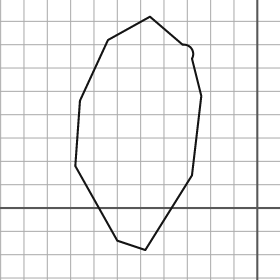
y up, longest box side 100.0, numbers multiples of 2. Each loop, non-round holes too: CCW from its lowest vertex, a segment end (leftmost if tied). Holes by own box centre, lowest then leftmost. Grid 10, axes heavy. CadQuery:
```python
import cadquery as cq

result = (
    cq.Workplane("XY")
    .moveTo(-48.0, -18.0)
    .lineTo(-28.0, 14.0)
    .lineTo(-24.0, 48.0)
    .lineTo(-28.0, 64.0)
    .threePointArc((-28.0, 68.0), (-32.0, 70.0))
    .lineTo(-46.0, 82.0)
    .lineTo(-64.0, 72.0)
    .lineTo(-76.0, 46.0)
    .lineTo(-78.0, 18.0)
    .lineTo(-60.0, -14.0)
    .close()
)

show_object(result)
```